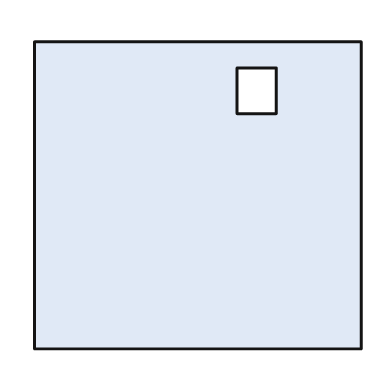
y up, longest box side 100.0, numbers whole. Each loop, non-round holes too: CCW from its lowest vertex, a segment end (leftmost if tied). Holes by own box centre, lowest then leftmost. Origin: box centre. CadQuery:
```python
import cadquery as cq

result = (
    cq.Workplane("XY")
    .moveTo(-50.0, -47.0)
    .lineTo(50.0, -47.0)
    .lineTo(50.0, 47.0)
    .lineTo(-50.0, 47.0)
    .close()
    .moveTo(12.0, 25.0)
    .lineTo(24.0, 25.0)
    .lineTo(24.0, 39.0)
    .lineTo(12.0, 39.0)
    .close()
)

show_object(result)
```